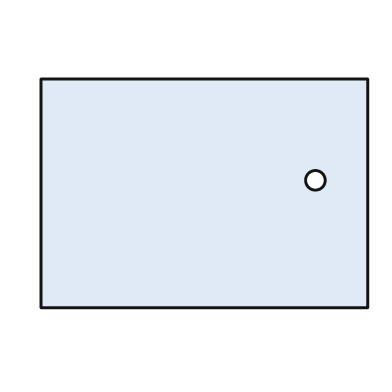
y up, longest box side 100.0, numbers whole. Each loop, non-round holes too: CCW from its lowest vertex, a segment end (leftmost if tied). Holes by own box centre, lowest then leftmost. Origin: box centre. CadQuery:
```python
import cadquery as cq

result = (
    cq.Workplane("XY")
    .moveTo(-50.0, -35.0)
    .lineTo(50.0, -35.0)
    .lineTo(50.0, 35.0)
    .lineTo(-50.0, 35.0)
    .close()
    .moveTo(34.0, 4.0)
    .circle(3.0)
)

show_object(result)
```